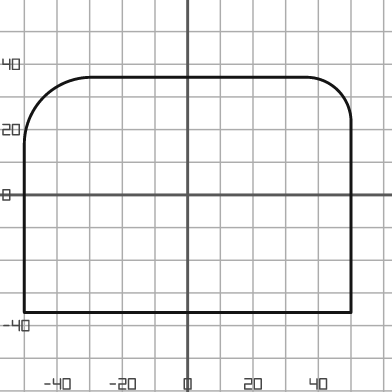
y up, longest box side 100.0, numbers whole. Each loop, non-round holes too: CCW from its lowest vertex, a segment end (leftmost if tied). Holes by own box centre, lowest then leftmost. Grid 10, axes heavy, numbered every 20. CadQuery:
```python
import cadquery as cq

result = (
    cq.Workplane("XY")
    .moveTo(-50.0, -36.0)
    .lineTo(50.0, -36.0)
    .lineTo(50.0, 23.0)
    .threePointArc((46.0, 32.0), (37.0, 36.0))
    .lineTo(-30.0, 36.0)
    .threePointArc((-44.0, 30.0), (-50.0, 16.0))
    .close()
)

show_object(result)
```